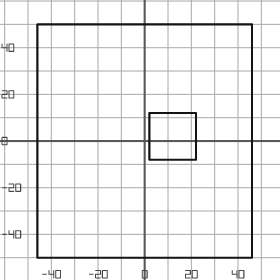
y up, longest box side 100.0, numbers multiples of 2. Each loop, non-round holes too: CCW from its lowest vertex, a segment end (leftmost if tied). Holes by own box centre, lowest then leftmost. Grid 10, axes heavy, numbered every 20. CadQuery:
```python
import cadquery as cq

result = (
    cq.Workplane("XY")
    .moveTo(-46.0, -50.0)
    .lineTo(46.0, -50.0)
    .lineTo(46.0, 50.0)
    .lineTo(-46.0, 50.0)
    .close()
    .moveTo(2.0, -8.0)
    .lineTo(22.0, -8.0)
    .lineTo(22.0, 12.0)
    .lineTo(2.0, 12.0)
    .close()
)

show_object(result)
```